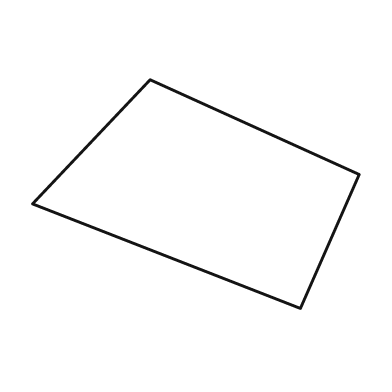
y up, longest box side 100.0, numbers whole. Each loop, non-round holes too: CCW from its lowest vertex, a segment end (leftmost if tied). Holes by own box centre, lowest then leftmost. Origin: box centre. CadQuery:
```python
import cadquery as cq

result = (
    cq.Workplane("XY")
    .moveTo(32.0, -35.0)
    .lineTo(50.0, 6.0)
    .lineTo(-14.0, 35.0)
    .lineTo(-50.0, -3.0)
    .close()
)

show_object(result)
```